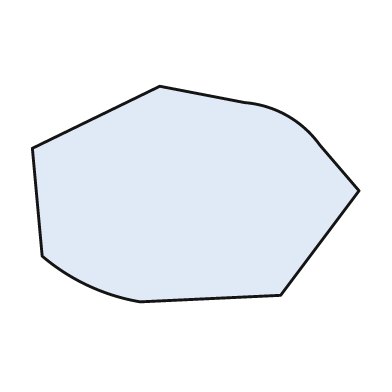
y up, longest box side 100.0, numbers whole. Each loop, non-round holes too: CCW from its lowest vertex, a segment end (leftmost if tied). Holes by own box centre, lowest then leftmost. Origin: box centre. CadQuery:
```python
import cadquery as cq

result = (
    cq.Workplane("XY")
    .moveTo(-17.0, -33.0)
    .lineTo(26.0, -31.0)
    .lineTo(50.0, 1.0)
    .lineTo(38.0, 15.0)
    .threePointArc((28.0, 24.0), (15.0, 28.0))
    .lineTo(-11.0, 33.0)
    .lineTo(-50.0, 14.0)
    .lineTo(-47.0, -19.0)
    .threePointArc((-33.0, -28.0), (-17.0, -33.0))
    .close()
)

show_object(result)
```